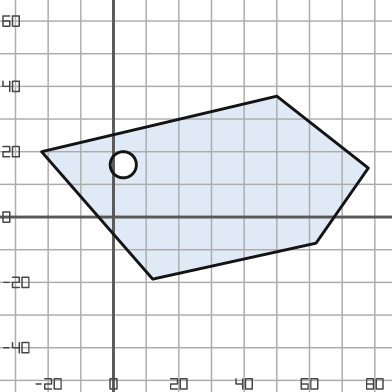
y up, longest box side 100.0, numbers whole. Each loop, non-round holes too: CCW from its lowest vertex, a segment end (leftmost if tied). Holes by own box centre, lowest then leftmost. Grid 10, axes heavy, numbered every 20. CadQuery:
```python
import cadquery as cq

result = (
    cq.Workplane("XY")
    .moveTo(12.0, -19.0)
    .lineTo(62.0, -8.0)
    .lineTo(78.0, 15.0)
    .lineTo(50.0, 37.0)
    .lineTo(-22.0, 20.0)
    .close()
    .moveTo(3.0, 16.0)
    .circle(4.0)
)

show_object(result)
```